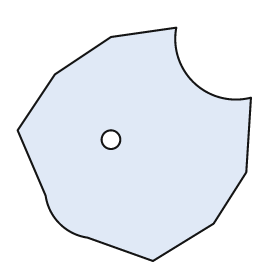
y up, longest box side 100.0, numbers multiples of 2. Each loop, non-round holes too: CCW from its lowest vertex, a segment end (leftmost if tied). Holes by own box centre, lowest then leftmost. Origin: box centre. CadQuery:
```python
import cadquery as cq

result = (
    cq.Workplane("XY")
    .moveTo(8.0, -50.0)
    .lineTo(34.0, -34.0)
    .lineTo(48.0, -12.0)
    .lineTo(50.0, 20.0)
    .threePointArc((26.0, 26.0), (18.0, 50.0))
    .lineTo(-10.0, 46.0)
    .lineTo(-34.0, 30.0)
    .lineTo(-50.0, 6.0)
    .lineTo(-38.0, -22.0)
    .threePointArc((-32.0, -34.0), (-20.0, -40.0))
    .close()
    .moveTo(-10.0, 2.0)
    .circle(4.0)
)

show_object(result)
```